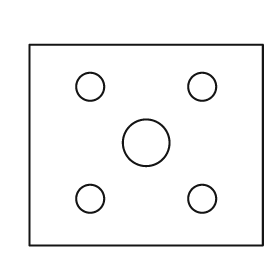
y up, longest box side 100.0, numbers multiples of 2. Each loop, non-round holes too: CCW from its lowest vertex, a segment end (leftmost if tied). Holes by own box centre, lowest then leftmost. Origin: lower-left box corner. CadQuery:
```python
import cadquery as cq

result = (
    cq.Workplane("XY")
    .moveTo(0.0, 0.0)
    .lineTo(100.0, 0.0)
    .lineTo(100.0, 86.0)
    .lineTo(0.0, 86.0)
    .close()
    .moveTo(26.0, 20.0)
    .circle(6.0)
    .moveTo(74.0, 20.0)
    .circle(6.0)
    .moveTo(50.0, 44.0)
    .circle(10.0)
    .moveTo(26.0, 68.0)
    .circle(6.0)
    .moveTo(74.0, 68.0)
    .circle(6.0)
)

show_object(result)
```